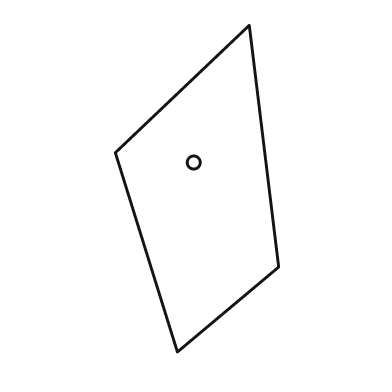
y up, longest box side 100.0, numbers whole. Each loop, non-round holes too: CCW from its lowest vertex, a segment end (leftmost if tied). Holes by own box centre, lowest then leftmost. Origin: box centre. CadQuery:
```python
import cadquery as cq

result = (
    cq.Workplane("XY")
    .moveTo(-6.0, -50.0)
    .lineTo(25.0, -24.0)
    .lineTo(16.0, 50.0)
    .lineTo(-25.0, 11.0)
    .close()
    .moveTo(-1.0, 8.0)
    .circle(2.0)
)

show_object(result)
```